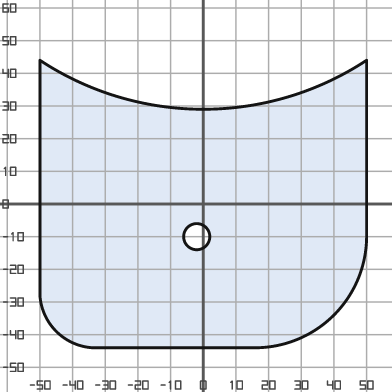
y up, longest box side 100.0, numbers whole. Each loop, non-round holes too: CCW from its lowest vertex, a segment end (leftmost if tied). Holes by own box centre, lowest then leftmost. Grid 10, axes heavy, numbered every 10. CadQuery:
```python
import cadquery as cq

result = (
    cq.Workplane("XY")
    .moveTo(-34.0, -44.0)
    .lineTo(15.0, -44.0)
    .threePointArc((40.0, -34.0), (50.0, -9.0))
    .lineTo(50.0, 44.0)
    .threePointArc((0.0, 29.0), (-50.0, 44.0))
    .lineTo(-50.0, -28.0)
    .threePointArc((-45.0, -39.0), (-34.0, -44.0))
    .close()
    .moveTo(-2.0, -10.0)
    .circle(4.0)
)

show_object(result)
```